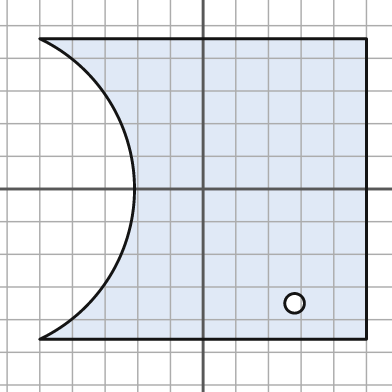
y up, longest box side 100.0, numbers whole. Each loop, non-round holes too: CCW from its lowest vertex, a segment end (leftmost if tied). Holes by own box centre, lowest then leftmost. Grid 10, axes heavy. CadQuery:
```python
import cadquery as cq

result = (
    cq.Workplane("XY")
    .moveTo(-50.0, -46.0)
    .lineTo(50.0, -46.0)
    .lineTo(50.0, 46.0)
    .lineTo(-50.0, 46.0)
    .threePointArc((-21.0, 0.0), (-50.0, -46.0))
    .close()
    .moveTo(28.0, -35.0)
    .circle(3.0)
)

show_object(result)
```